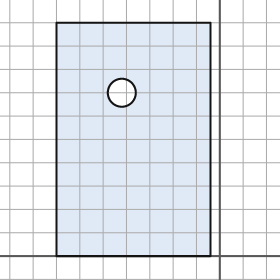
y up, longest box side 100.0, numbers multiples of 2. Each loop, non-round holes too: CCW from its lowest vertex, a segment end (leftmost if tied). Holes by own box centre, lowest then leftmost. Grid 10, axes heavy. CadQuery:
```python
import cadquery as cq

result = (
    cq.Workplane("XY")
    .moveTo(-70.0, 0.0)
    .lineTo(-4.0, 0.0)
    .lineTo(-4.0, 100.0)
    .lineTo(-70.0, 100.0)
    .close()
    .moveTo(-42.0, 70.0)
    .circle(6.0)
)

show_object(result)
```